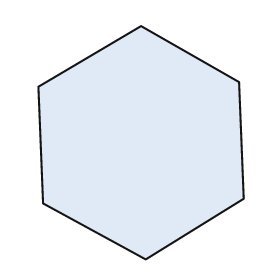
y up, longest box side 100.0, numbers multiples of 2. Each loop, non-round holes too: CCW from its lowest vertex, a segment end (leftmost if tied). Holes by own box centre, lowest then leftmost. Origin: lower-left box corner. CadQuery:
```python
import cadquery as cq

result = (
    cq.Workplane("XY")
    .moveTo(46.0, 0.0)
    .lineTo(88.0, 26.0)
    .lineTo(86.0, 76.0)
    .lineTo(44.0, 100.0)
    .lineTo(0.0, 74.0)
    .lineTo(2.0, 24.0)
    .close()
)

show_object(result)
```